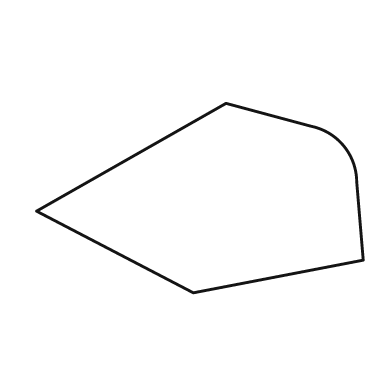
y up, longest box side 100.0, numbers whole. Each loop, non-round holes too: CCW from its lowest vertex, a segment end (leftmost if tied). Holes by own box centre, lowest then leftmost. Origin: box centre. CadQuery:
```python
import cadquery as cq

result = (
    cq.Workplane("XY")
    .moveTo(-2.0, -29.0)
    .lineTo(50.0, -19.0)
    .lineTo(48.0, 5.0)
    .threePointArc((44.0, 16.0), (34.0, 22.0))
    .lineTo(8.0, 29.0)
    .lineTo(-50.0, -4.0)
    .close()
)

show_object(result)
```